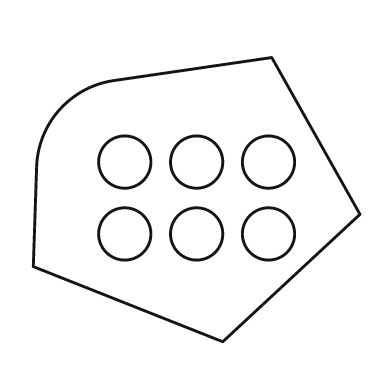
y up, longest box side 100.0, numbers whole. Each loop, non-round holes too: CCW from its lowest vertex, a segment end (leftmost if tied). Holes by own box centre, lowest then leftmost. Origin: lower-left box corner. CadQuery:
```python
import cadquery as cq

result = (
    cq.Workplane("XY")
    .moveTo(58.0, 0.0)
    .lineTo(100.0, 39.0)
    .lineTo(73.0, 87.0)
    .lineTo(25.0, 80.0)
    .threePointArc((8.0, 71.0), (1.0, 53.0))
    .lineTo(0.0, 23.0)
    .close()
    .moveTo(28.0, 33.0)
    .circle(8.0)
    .moveTo(50.0, 33.0)
    .circle(8.0)
    .moveTo(72.0, 33.0)
    .circle(8.0)
    .moveTo(28.0, 55.0)
    .circle(8.0)
    .moveTo(50.0, 55.0)
    .circle(8.0)
    .moveTo(72.0, 55.0)
    .circle(8.0)
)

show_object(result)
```